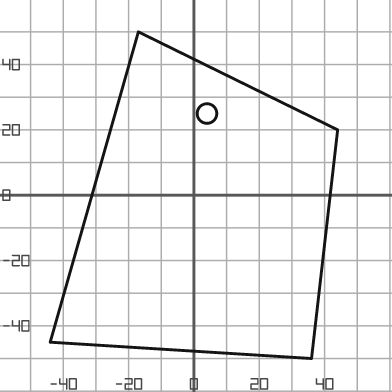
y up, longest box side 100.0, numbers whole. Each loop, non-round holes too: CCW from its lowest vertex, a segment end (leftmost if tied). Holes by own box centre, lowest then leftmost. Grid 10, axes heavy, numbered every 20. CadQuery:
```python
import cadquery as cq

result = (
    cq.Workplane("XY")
    .moveTo(36.0, -50.0)
    .lineTo(44.0, 20.0)
    .lineTo(-17.0, 50.0)
    .lineTo(-44.0, -45.0)
    .close()
    .moveTo(4.0, 25.0)
    .circle(3.0)
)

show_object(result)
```